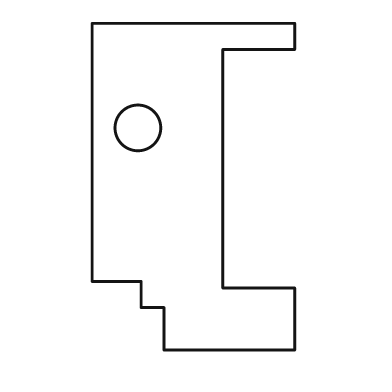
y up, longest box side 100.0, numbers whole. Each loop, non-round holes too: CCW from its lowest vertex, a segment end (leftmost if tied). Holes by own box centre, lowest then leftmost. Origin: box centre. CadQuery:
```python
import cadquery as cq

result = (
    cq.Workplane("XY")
    .moveTo(-9.0, -50.0)
    .lineTo(31.0, -50.0)
    .lineTo(31.0, -31.0)
    .lineTo(9.0, -31.0)
    .lineTo(9.0, 42.0)
    .lineTo(31.0, 42.0)
    .lineTo(31.0, 50.0)
    .lineTo(-31.0, 50.0)
    .lineTo(-31.0, -29.0)
    .lineTo(-16.0, -29.0)
    .lineTo(-16.0, -37.0)
    .lineTo(-9.0, -37.0)
    .close()
    .moveTo(-17.0, 18.0)
    .circle(7.0)
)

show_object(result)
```